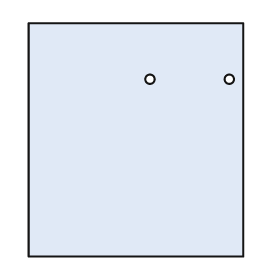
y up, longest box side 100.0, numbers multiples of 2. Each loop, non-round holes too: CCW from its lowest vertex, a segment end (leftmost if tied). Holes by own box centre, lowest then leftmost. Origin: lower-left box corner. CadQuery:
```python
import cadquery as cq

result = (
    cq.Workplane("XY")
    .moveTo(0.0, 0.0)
    .lineTo(92.0, 0.0)
    .lineTo(92.0, 100.0)
    .lineTo(0.0, 100.0)
    .close()
    .moveTo(52.0, 76.0)
    .circle(2.0)
    .moveTo(86.0, 76.0)
    .circle(2.0)
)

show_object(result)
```